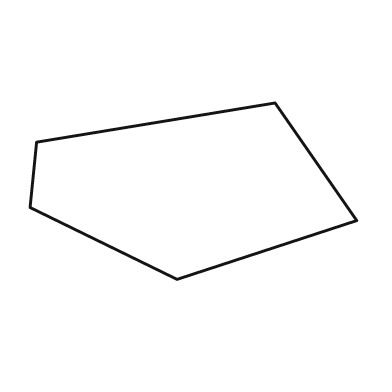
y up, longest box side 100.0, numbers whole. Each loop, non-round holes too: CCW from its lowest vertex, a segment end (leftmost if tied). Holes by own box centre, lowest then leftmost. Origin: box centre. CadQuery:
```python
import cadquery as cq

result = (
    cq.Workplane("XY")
    .moveTo(-5.0, -27.0)
    .lineTo(50.0, -9.0)
    .lineTo(25.0, 27.0)
    .lineTo(-48.0, 15.0)
    .lineTo(-50.0, -5.0)
    .close()
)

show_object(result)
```